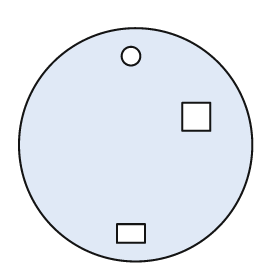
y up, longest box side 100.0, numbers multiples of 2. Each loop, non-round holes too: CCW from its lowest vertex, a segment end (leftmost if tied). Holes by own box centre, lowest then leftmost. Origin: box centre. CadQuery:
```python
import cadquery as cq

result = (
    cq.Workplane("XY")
    .moveTo(0.0, 0.0)
    .circle(50.0)
    .moveTo(-8.0, -42.0)
    .lineTo(4.0, -42.0)
    .lineTo(4.0, -34.0)
    .lineTo(-8.0, -34.0)
    .close()
    .moveTo(20.0, 6.0)
    .lineTo(32.0, 6.0)
    .lineTo(32.0, 18.0)
    .lineTo(20.0, 18.0)
    .close()
    .moveTo(-2.0, 38.0)
    .circle(4.0)
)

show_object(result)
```